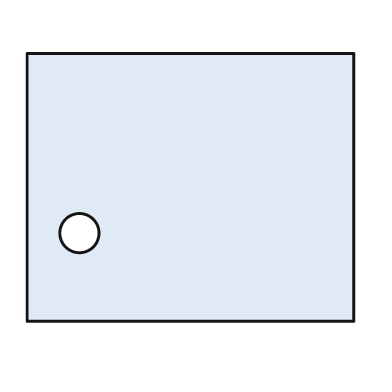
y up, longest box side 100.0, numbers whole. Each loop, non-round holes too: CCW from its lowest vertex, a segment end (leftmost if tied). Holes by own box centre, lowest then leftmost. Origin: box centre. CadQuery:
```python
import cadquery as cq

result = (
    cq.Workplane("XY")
    .moveTo(-50.0, -41.0)
    .lineTo(50.0, -41.0)
    .lineTo(50.0, 41.0)
    .lineTo(-50.0, 41.0)
    .close()
    .moveTo(-34.0, -14.0)
    .circle(6.0)
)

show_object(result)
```